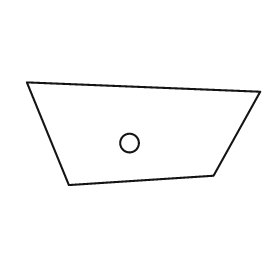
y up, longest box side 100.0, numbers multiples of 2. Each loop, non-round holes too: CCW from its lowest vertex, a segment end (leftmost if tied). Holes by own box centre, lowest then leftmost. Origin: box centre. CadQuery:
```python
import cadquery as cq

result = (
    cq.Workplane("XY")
    .moveTo(-32.0, -22.0)
    .lineTo(30.0, -18.0)
    .lineTo(50.0, 18.0)
    .lineTo(-50.0, 22.0)
    .close()
    .moveTo(-6.0, -4.0)
    .circle(4.0)
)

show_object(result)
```